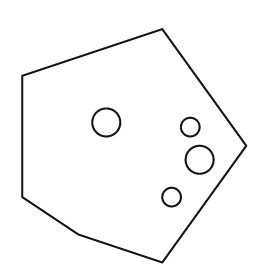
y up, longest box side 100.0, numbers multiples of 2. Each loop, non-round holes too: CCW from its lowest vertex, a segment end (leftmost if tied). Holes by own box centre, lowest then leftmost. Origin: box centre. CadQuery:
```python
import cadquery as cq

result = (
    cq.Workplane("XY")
    .moveTo(12.0, -50.0)
    .lineTo(48.0, 0.0)
    .lineTo(12.0, 50.0)
    .lineTo(-48.0, 30.0)
    .lineTo(-48.0, -22.0)
    .lineTo(-24.0, -38.0)
    .close()
    .moveTo(16.0, -22.0)
    .circle(4.0)
    .moveTo(28.0, -6.0)
    .circle(6.0)
    .moveTo(24.0, 8.0)
    .circle(4.0)
    .moveTo(-12.0, 10.0)
    .circle(6.0)
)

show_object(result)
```